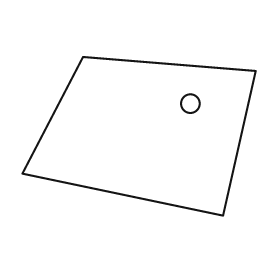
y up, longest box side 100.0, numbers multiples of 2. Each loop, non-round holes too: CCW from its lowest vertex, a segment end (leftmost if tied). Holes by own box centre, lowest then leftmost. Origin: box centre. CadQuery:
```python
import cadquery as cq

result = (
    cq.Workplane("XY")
    .moveTo(36.0, -34.0)
    .lineTo(50.0, 28.0)
    .lineTo(-24.0, 34.0)
    .lineTo(-50.0, -16.0)
    .close()
    .moveTo(22.0, 14.0)
    .circle(4.0)
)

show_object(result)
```